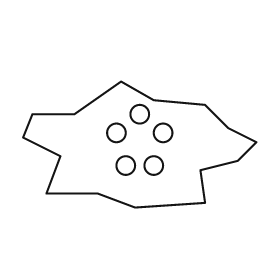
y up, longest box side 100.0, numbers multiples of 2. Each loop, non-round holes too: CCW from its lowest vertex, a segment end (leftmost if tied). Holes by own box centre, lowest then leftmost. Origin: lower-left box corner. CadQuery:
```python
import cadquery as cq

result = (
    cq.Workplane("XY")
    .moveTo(48.0, 0.0)
    .lineTo(78.0, 2.0)
    .lineTo(76.0, 16.0)
    .lineTo(92.0, 20.0)
    .lineTo(100.0, 28.0)
    .lineTo(88.0, 34.0)
    .lineTo(78.0, 44.0)
    .lineTo(56.0, 46.0)
    .lineTo(42.0, 54.0)
    .lineTo(22.0, 40.0)
    .lineTo(4.0, 40.0)
    .lineTo(0.0, 30.0)
    .lineTo(16.0, 22.0)
    .lineTo(10.0, 6.0)
    .lineTo(32.0, 6.0)
    .close()
    .moveTo(44.0, 18.0)
    .circle(4.0)
    .moveTo(56.0, 18.0)
    .circle(4.0)
    .moveTo(40.0, 32.0)
    .circle(4.0)
    .moveTo(60.0, 32.0)
    .circle(4.0)
    .moveTo(50.0, 40.0)
    .circle(4.0)
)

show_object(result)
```